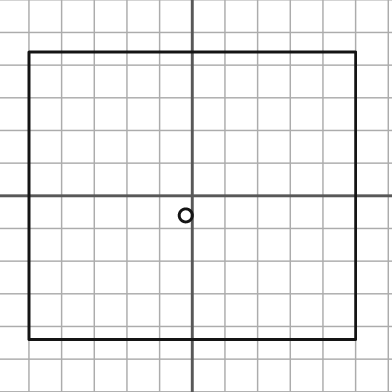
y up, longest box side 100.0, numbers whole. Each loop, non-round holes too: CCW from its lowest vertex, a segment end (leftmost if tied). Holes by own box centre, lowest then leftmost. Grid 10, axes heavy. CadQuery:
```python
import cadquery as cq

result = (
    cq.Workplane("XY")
    .moveTo(-50.0, -44.0)
    .lineTo(50.0, -44.0)
    .lineTo(50.0, 44.0)
    .lineTo(-50.0, 44.0)
    .close()
    .moveTo(-2.0, -6.0)
    .circle(2.0)
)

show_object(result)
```